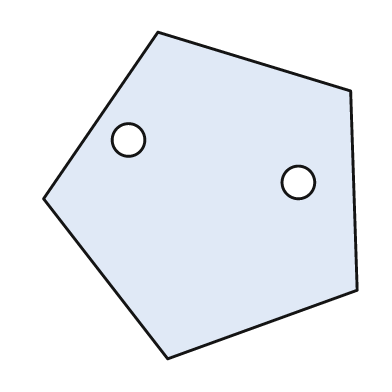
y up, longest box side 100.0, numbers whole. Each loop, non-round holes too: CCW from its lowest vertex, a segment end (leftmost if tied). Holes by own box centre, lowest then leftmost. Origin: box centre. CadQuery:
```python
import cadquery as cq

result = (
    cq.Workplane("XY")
    .moveTo(-10.0, -50.0)
    .lineTo(48.0, -29.0)
    .lineTo(46.0, 32.0)
    .lineTo(-13.0, 50.0)
    .lineTo(-48.0, -1.0)
    .close()
    .moveTo(30.0, 4.0)
    .circle(5.0)
    .moveTo(-22.0, 17.0)
    .circle(5.0)
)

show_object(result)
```